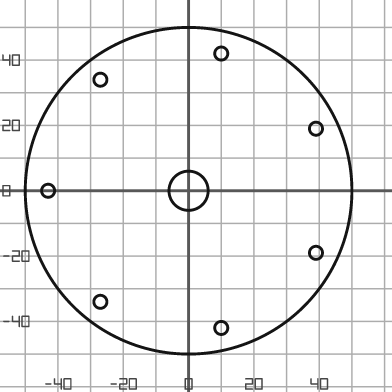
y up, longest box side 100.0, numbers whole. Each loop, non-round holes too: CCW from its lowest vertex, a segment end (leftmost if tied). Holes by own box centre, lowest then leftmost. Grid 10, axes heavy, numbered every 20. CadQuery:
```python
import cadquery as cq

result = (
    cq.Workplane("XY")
    .moveTo(0.0, 0.0)
    .circle(50.0)
    .moveTo(10.0, -42.0)
    .circle(2.0)
    .moveTo(-27.0, -34.0)
    .circle(2.0)
    .moveTo(39.0, -19.0)
    .circle(2.0)
    .moveTo(-43.0, 0.0)
    .circle(2.0)
    .moveTo(0.0, 0.0)
    .circle(6.0)
    .moveTo(39.0, 19.0)
    .circle(2.0)
    .moveTo(-27.0, 34.0)
    .circle(2.0)
    .moveTo(10.0, 42.0)
    .circle(2.0)
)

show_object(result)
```